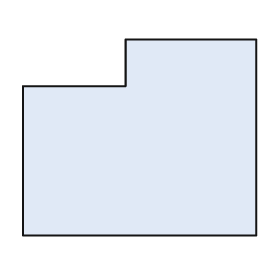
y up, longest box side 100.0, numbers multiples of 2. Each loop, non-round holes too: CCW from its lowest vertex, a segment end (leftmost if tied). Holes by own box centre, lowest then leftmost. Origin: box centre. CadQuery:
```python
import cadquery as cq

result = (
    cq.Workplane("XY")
    .moveTo(-50.0, -42.0)
    .lineTo(50.0, -42.0)
    .lineTo(50.0, 42.0)
    .lineTo(-6.0, 42.0)
    .lineTo(-6.0, 22.0)
    .lineTo(-50.0, 22.0)
    .close()
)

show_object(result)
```